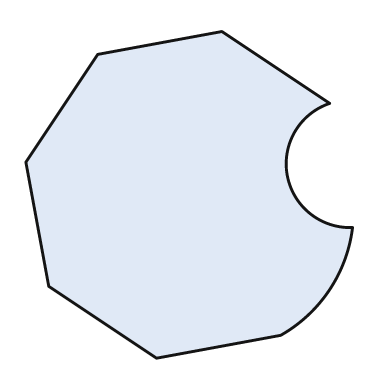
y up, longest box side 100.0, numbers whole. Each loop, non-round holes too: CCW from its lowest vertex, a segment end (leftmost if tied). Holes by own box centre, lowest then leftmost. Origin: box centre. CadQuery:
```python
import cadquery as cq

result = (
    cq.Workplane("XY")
    .moveTo(-10.0, -50.0)
    .lineTo(28.0, -43.0)
    .threePointArc((43.0, -29.0), (50.0, -10.0))
    .threePointArc((30.0, 6.0), (43.0, 28.0))
    .lineTo(10.0, 50.0)
    .lineTo(-28.0, 43.0)
    .lineTo(-50.0, 10.0)
    .lineTo(-43.0, -28.0)
    .close()
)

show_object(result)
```